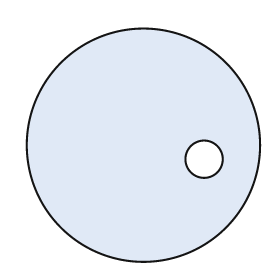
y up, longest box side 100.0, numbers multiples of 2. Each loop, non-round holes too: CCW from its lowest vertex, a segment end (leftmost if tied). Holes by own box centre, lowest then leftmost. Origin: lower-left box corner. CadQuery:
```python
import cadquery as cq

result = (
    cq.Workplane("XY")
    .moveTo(50.0, 50.0)
    .circle(50.0)
    .moveTo(76.0, 44.0)
    .circle(8.0)
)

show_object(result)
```